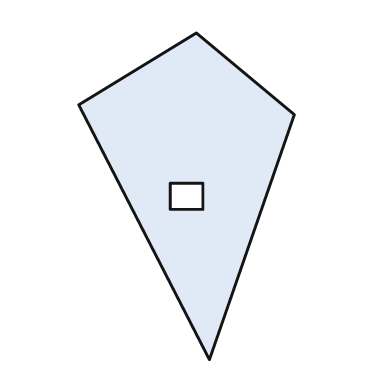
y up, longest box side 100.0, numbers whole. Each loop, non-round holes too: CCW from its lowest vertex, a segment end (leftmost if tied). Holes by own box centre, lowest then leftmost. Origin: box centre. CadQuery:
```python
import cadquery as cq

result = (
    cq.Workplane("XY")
    .moveTo(7.0, -50.0)
    .lineTo(33.0, 25.0)
    .lineTo(3.0, 50.0)
    .lineTo(-33.0, 28.0)
    .close()
    .moveTo(-5.0, -4.0)
    .lineTo(5.0, -4.0)
    .lineTo(5.0, 4.0)
    .lineTo(-5.0, 4.0)
    .close()
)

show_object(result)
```